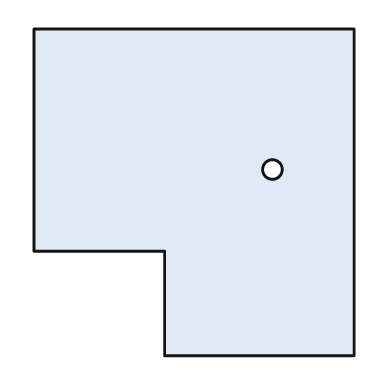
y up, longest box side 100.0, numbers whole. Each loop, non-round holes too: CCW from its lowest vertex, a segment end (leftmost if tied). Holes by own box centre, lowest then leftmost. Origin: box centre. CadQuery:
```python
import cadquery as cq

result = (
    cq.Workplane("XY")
    .moveTo(-9.0, -50.0)
    .lineTo(49.0, -50.0)
    .lineTo(49.0, 50.0)
    .lineTo(-49.0, 50.0)
    .lineTo(-49.0, -18.0)
    .lineTo(-9.0, -18.0)
    .close()
    .moveTo(24.0, 7.0)
    .circle(3.0)
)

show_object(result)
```